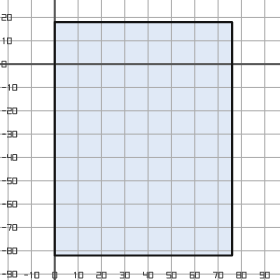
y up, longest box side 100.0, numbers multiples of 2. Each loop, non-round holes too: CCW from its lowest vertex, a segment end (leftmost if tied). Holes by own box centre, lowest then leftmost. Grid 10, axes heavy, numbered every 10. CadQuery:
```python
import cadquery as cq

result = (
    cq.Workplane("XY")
    .moveTo(0.0, -82.0)
    .lineTo(76.0, -82.0)
    .lineTo(76.0, 18.0)
    .lineTo(0.0, 18.0)
    .close()
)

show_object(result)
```